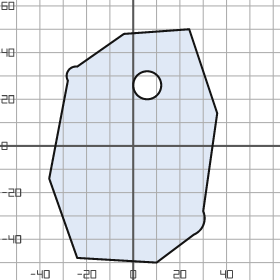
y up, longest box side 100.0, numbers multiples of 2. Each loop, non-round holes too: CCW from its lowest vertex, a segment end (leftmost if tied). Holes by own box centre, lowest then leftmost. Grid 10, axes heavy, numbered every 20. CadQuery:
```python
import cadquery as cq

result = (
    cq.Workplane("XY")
    .moveTo(10.0, -50.0)
    .lineTo(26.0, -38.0)
    .threePointArc((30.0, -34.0), (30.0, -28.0))
    .lineTo(36.0, 14.0)
    .lineTo(24.0, 50.0)
    .lineTo(-4.0, 48.0)
    .lineTo(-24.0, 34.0)
    .threePointArc((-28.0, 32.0), (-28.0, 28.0))
    .lineTo(-36.0, -14.0)
    .lineTo(-24.0, -48.0)
    .close()
    .moveTo(6.0, 26.0)
    .circle(6.0)
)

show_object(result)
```